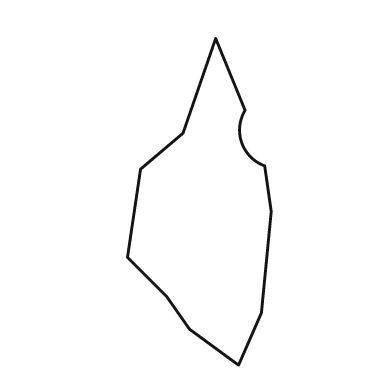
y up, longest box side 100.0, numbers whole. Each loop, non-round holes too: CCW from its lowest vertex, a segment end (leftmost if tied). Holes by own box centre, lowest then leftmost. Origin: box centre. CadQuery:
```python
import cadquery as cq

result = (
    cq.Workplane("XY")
    .moveTo(12.0, -50.0)
    .lineTo(19.0, -34.0)
    .lineTo(22.0, -3.0)
    .lineTo(20.0, 11.0)
    .threePointArc((13.0, 18.0), (14.0, 28.0))
    .lineTo(5.0, 50.0)
    .lineTo(-5.0, 21.0)
    .lineTo(-18.0, 10.0)
    .lineTo(-22.0, -17.0)
    .lineTo(-10.0, -29.0)
    .lineTo(-3.0, -39.0)
    .close()
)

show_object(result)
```